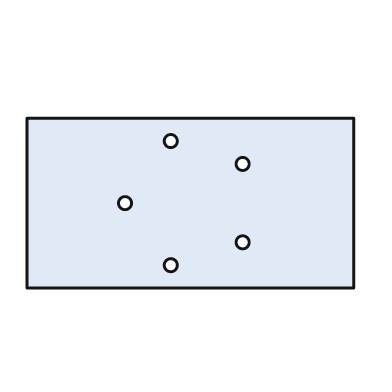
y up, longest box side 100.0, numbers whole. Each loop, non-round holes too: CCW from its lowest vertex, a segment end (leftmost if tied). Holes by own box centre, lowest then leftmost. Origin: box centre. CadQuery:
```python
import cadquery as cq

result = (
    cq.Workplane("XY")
    .moveTo(-50.0, -26.0)
    .lineTo(50.0, -26.0)
    .lineTo(50.0, 26.0)
    .lineTo(-50.0, 26.0)
    .close()
    .moveTo(-6.0, -19.0)
    .circle(2.0)
    .moveTo(16.0, -12.0)
    .circle(2.0)
    .moveTo(-20.0, 0.0)
    .circle(2.0)
    .moveTo(16.0, 12.0)
    .circle(2.0)
    .moveTo(-6.0, 19.0)
    .circle(2.0)
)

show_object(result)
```